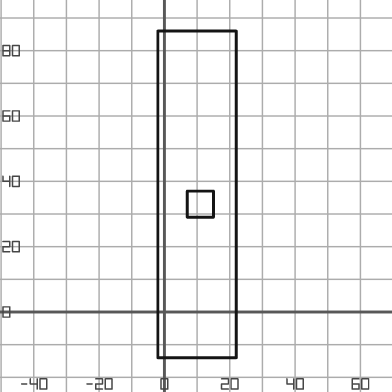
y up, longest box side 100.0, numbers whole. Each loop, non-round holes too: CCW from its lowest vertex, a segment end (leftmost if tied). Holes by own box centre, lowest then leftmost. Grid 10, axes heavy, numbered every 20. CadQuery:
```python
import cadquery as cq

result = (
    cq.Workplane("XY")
    .moveTo(-2.0, -14.0)
    .lineTo(22.0, -14.0)
    .lineTo(22.0, 86.0)
    .lineTo(-2.0, 86.0)
    .close()
    .moveTo(7.0, 29.0)
    .lineTo(15.0, 29.0)
    .lineTo(15.0, 37.0)
    .lineTo(7.0, 37.0)
    .close()
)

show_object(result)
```